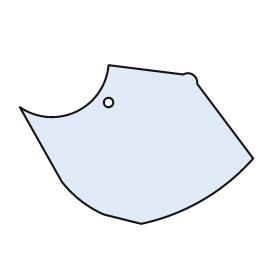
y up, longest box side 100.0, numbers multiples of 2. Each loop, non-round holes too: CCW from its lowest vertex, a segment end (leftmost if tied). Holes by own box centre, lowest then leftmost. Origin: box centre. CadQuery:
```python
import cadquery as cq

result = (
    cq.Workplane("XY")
    .moveTo(2.0, -34.0)
    .threePointArc((28.0, -24.0), (50.0, -6.0))
    .lineTo(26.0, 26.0)
    .threePointArc((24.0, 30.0), (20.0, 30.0))
    .lineTo(-12.0, 34.0)
    .threePointArc((-26.0, 14.0), (-50.0, 16.0))
    .lineTo(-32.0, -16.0)
    .threePointArc((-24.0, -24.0), (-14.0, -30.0))
    .close()
    .moveTo(-12.0, 18.0)
    .circle(2.0)
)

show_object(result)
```